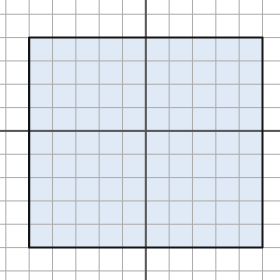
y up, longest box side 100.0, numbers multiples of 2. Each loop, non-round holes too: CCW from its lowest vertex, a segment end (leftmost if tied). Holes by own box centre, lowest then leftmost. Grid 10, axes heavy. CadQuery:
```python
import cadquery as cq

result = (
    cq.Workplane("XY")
    .moveTo(-50.0, -50.0)
    .lineTo(50.0, -50.0)
    .lineTo(50.0, 40.0)
    .lineTo(-50.0, 40.0)
    .close()
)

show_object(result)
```